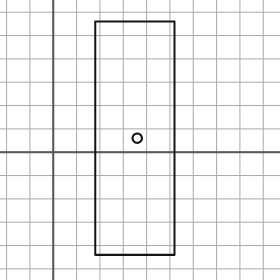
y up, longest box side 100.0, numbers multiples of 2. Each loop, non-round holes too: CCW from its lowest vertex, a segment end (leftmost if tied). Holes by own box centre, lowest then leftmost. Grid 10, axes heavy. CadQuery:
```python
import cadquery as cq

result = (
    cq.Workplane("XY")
    .moveTo(18.0, -44.0)
    .lineTo(52.0, -44.0)
    .lineTo(52.0, 56.0)
    .lineTo(18.0, 56.0)
    .close()
    .moveTo(36.0, 6.0)
    .circle(2.0)
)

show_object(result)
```